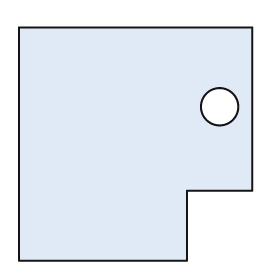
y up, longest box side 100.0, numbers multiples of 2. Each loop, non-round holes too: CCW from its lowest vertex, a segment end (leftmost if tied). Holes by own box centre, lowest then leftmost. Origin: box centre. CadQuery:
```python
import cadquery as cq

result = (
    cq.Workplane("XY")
    .moveTo(-50.0, -50.0)
    .lineTo(22.0, -50.0)
    .lineTo(22.0, -20.0)
    .lineTo(50.0, -20.0)
    .lineTo(50.0, 50.0)
    .lineTo(-50.0, 50.0)
    .close()
    .moveTo(36.0, 16.0)
    .circle(8.0)
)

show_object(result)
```